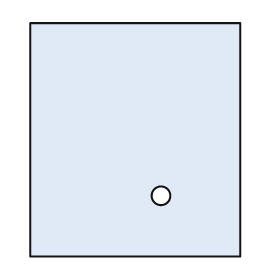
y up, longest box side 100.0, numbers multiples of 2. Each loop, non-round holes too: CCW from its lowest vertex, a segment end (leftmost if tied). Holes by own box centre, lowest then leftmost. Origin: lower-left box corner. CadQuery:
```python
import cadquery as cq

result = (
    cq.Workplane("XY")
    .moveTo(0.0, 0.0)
    .lineTo(90.0, 0.0)
    .lineTo(90.0, 100.0)
    .lineTo(0.0, 100.0)
    .close()
    .moveTo(56.0, 26.0)
    .circle(4.0)
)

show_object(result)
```